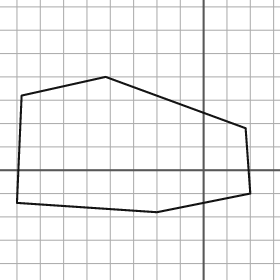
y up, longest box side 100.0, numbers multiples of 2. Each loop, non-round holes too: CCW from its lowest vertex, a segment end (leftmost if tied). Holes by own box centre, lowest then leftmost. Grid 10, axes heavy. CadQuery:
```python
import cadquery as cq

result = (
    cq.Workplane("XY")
    .moveTo(-20.0, -18.0)
    .lineTo(20.0, -10.0)
    .lineTo(18.0, 18.0)
    .lineTo(-42.0, 40.0)
    .lineTo(-78.0, 32.0)
    .lineTo(-80.0, -14.0)
    .close()
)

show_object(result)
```